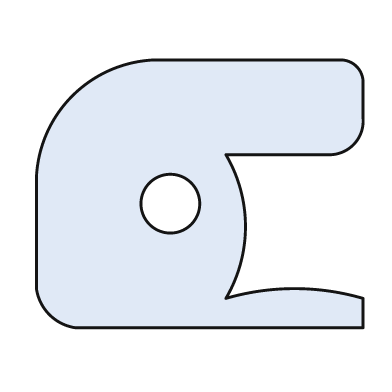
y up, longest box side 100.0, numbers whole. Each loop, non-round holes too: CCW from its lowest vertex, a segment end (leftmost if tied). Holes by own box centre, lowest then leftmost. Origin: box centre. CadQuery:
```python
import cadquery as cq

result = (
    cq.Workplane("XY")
    .moveTo(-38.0, -41.0)
    .lineTo(50.0, -41.0)
    .lineTo(50.0, -32.0)
    .threePointArc((29.0, -29.0), (8.0, -32.0))
    .threePointArc((14.0, -10.0), (8.0, 12.0))
    .lineTo(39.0, 12.0)
    .threePointArc((47.0, 15.0), (50.0, 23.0))
    .lineTo(50.0, 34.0)
    .threePointArc((48.0, 39.0), (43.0, 41.0))
    .lineTo(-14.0, 41.0)
    .threePointArc((-39.0, 30.0), (-50.0, 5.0))
    .lineTo(-50.0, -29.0)
    .threePointArc((-46.0, -37.0), (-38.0, -41.0))
    .close()
    .moveTo(-9.0, -3.0)
    .circle(9.0)
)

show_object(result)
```